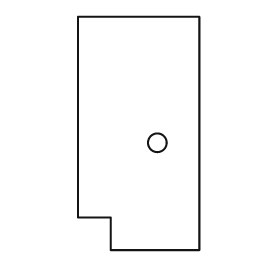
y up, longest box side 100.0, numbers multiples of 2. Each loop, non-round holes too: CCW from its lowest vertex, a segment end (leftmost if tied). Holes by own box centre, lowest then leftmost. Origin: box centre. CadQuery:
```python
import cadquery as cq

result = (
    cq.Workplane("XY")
    .moveTo(-12.0, -50.0)
    .lineTo(26.0, -50.0)
    .lineTo(26.0, 50.0)
    .lineTo(-26.0, 50.0)
    .lineTo(-26.0, -36.0)
    .lineTo(-12.0, -36.0)
    .close()
    .moveTo(8.0, -4.0)
    .circle(4.0)
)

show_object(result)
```